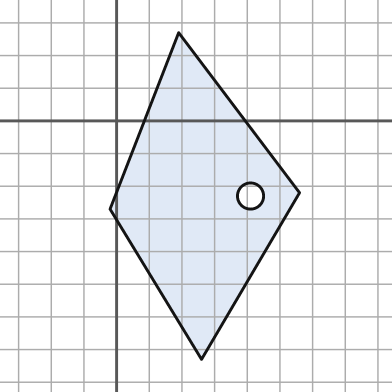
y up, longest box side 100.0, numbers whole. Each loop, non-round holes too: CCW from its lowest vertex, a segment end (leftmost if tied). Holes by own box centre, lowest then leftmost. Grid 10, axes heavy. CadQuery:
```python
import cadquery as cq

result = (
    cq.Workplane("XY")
    .moveTo(26.0, -73.0)
    .lineTo(56.0, -22.0)
    .lineTo(19.0, 27.0)
    .lineTo(-2.0, -27.0)
    .close()
    .moveTo(41.0, -23.0)
    .circle(4.0)
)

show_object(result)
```